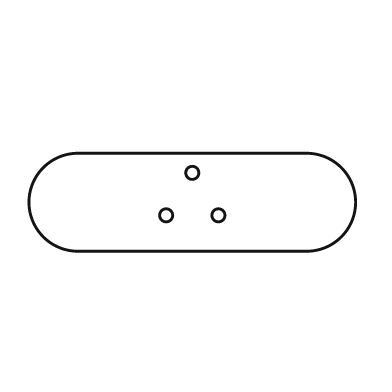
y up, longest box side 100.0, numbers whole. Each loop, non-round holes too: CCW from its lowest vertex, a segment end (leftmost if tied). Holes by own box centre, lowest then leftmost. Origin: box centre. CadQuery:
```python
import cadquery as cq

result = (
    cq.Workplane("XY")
    .moveTo(-35.0, -15.0)
    .lineTo(35.0, -15.0)
    .threePointArc((50.0, 0.0), (35.0, 15.0))
    .lineTo(-35.0, 15.0)
    .threePointArc((-50.0, 0.0), (-35.0, -15.0))
    .close()
    .moveTo(-8.0, -4.0)
    .circle(2.0)
    .moveTo(8.0, -4.0)
    .circle(2.0)
    .moveTo(0.0, 9.0)
    .circle(2.0)
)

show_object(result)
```